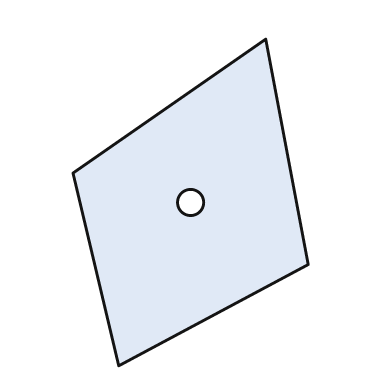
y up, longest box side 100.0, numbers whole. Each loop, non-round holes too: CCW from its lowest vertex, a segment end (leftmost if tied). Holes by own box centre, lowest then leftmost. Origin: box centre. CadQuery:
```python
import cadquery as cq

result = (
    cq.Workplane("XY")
    .moveTo(-22.0, -50.0)
    .lineTo(36.0, -19.0)
    .lineTo(23.0, 50.0)
    .lineTo(-36.0, 9.0)
    .close()
    .moveTo(0.0, 0.0)
    .circle(4.0)
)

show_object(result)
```